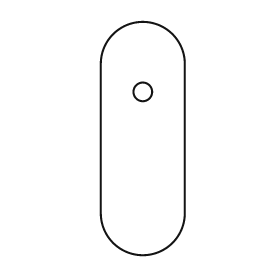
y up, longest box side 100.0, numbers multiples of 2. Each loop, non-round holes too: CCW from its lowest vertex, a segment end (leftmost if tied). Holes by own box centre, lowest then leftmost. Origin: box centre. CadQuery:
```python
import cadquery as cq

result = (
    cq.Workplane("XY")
    .moveTo(-18.0, -32.0)
    .threePointArc((0.0, -50.0), (18.0, -32.0))
    .lineTo(18.0, 32.0)
    .threePointArc((0.0, 50.0), (-18.0, 32.0))
    .close()
    .moveTo(0.0, 20.0)
    .circle(4.0)
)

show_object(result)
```